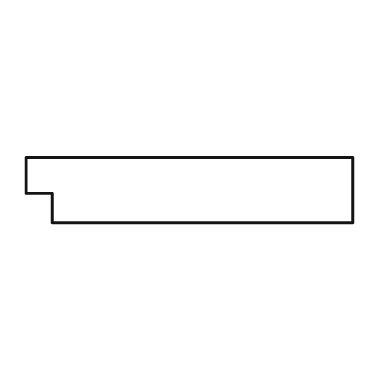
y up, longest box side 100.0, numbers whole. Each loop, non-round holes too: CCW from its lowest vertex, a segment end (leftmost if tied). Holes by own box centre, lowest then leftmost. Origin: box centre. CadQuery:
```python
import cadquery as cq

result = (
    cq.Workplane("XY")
    .moveTo(-42.0, -10.0)
    .lineTo(50.0, -10.0)
    .lineTo(50.0, 10.0)
    .lineTo(-50.0, 10.0)
    .lineTo(-50.0, -1.0)
    .lineTo(-42.0, -1.0)
    .close()
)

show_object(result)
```